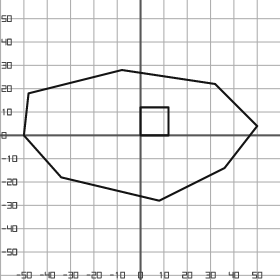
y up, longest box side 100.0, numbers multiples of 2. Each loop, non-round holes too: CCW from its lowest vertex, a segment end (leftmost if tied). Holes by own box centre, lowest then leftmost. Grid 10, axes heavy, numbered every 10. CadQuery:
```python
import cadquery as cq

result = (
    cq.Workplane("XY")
    .moveTo(8.0, -28.0)
    .lineTo(36.0, -14.0)
    .lineTo(50.0, 4.0)
    .lineTo(32.0, 22.0)
    .lineTo(-8.0, 28.0)
    .lineTo(-48.0, 18.0)
    .lineTo(-50.0, 0.0)
    .lineTo(-34.0, -18.0)
    .close()
    .moveTo(0.0, 0.0)
    .lineTo(12.0, 0.0)
    .lineTo(12.0, 12.0)
    .lineTo(0.0, 12.0)
    .close()
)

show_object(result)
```